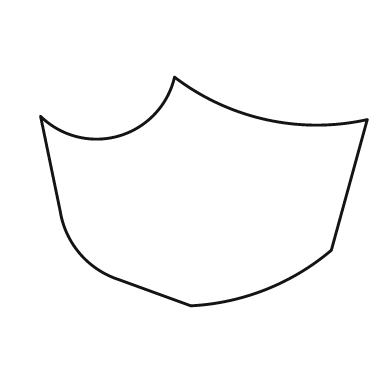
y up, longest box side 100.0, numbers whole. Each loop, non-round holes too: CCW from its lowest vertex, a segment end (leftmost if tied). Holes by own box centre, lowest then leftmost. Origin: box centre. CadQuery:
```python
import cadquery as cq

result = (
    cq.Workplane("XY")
    .moveTo(-4.0, -35.0)
    .threePointArc((19.0, -30.0), (39.0, -18.0))
    .lineTo(50.0, 22.0)
    .threePointArc((19.0, 22.0), (-9.0, 35.0))
    .threePointArc((-26.0, 17.0), (-50.0, 23.0))
    .lineTo(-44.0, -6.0)
    .threePointArc((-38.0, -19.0), (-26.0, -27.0))
    .close()
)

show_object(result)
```